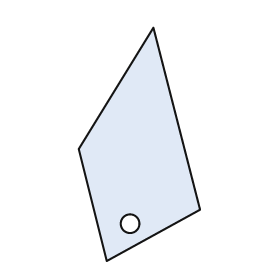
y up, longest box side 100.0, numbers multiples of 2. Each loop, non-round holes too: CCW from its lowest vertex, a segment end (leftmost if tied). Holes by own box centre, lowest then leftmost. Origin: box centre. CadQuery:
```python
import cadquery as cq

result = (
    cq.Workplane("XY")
    .moveTo(-14.0, -50.0)
    .lineTo(26.0, -28.0)
    .lineTo(6.0, 50.0)
    .lineTo(-26.0, -2.0)
    .close()
    .moveTo(-4.0, -34.0)
    .circle(4.0)
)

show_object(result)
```